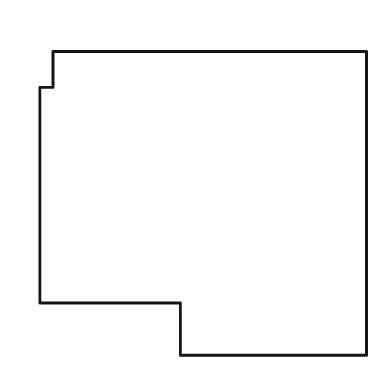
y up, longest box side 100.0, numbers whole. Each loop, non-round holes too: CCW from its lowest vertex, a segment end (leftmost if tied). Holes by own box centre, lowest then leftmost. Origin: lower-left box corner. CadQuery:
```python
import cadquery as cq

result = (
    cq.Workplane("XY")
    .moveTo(43.0, 0.0)
    .lineTo(100.0, 0.0)
    .lineTo(100.0, 93.0)
    .lineTo(4.0, 93.0)
    .lineTo(4.0, 82.0)
    .lineTo(0.0, 82.0)
    .lineTo(0.0, 16.0)
    .lineTo(43.0, 16.0)
    .close()
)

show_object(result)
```